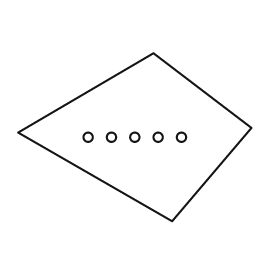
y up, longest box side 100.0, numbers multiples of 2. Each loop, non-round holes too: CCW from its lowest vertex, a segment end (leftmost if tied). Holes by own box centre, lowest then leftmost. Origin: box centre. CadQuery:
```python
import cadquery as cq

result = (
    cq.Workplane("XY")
    .moveTo(16.0, -36.0)
    .lineTo(50.0, 4.0)
    .lineTo(8.0, 36.0)
    .lineTo(-50.0, 2.0)
    .close()
    .moveTo(-20.0, 0.0)
    .circle(2.0)
    .moveTo(-10.0, 0.0)
    .circle(2.0)
    .moveTo(0.0, 0.0)
    .circle(2.0)
    .moveTo(10.0, 0.0)
    .circle(2.0)
    .moveTo(20.0, 0.0)
    .circle(2.0)
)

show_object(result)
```